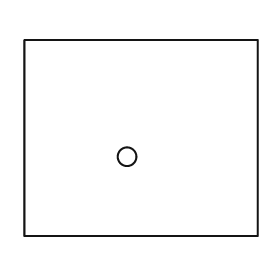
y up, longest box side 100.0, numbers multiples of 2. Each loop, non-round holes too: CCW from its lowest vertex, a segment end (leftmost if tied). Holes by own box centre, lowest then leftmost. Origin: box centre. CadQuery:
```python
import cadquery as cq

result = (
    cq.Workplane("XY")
    .moveTo(-50.0, -42.0)
    .lineTo(50.0, -42.0)
    .lineTo(50.0, 42.0)
    .lineTo(-50.0, 42.0)
    .close()
    .moveTo(-6.0, -8.0)
    .circle(4.0)
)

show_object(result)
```